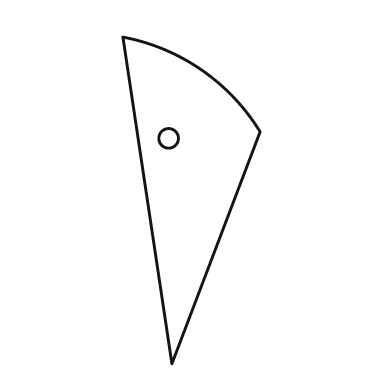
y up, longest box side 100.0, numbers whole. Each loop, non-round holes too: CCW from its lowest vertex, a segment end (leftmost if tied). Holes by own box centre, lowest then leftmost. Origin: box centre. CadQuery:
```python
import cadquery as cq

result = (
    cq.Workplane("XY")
    .moveTo(-6.0, -50.0)
    .lineTo(21.0, 21.0)
    .threePointArc((3.0, 40.0), (-21.0, 50.0))
    .close()
    .moveTo(-7.0, 19.0)
    .circle(3.0)
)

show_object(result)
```